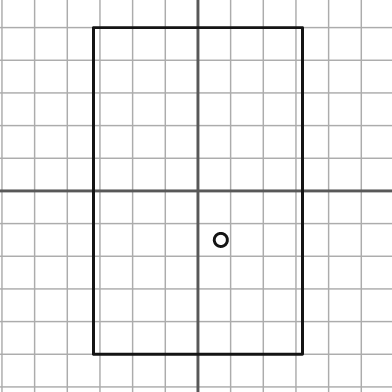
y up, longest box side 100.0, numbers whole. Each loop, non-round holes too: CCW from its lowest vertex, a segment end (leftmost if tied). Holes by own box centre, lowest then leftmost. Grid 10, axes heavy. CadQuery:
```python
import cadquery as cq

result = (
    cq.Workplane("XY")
    .moveTo(-32.0, -50.0)
    .lineTo(32.0, -50.0)
    .lineTo(32.0, 50.0)
    .lineTo(-32.0, 50.0)
    .close()
    .moveTo(7.0, -15.0)
    .circle(2.0)
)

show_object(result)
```